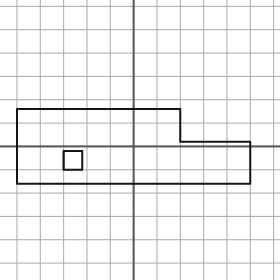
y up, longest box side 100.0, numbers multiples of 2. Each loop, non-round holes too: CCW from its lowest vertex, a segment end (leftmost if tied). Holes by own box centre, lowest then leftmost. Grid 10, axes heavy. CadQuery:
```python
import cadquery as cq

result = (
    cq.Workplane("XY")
    .moveTo(-50.0, -16.0)
    .lineTo(50.0, -16.0)
    .lineTo(50.0, 2.0)
    .lineTo(20.0, 2.0)
    .lineTo(20.0, 16.0)
    .lineTo(-50.0, 16.0)
    .close()
    .moveTo(-30.0, -10.0)
    .lineTo(-22.0, -10.0)
    .lineTo(-22.0, -2.0)
    .lineTo(-30.0, -2.0)
    .close()
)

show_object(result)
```